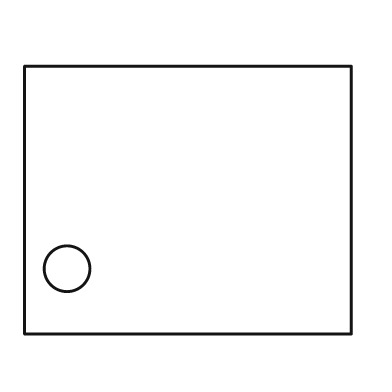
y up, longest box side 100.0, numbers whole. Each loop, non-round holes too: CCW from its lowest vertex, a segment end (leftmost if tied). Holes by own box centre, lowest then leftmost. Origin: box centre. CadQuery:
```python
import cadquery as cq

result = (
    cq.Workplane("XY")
    .moveTo(-50.0, -41.0)
    .lineTo(50.0, -41.0)
    .lineTo(50.0, 41.0)
    .lineTo(-50.0, 41.0)
    .close()
    .moveTo(-37.0, -21.0)
    .circle(7.0)
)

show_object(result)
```